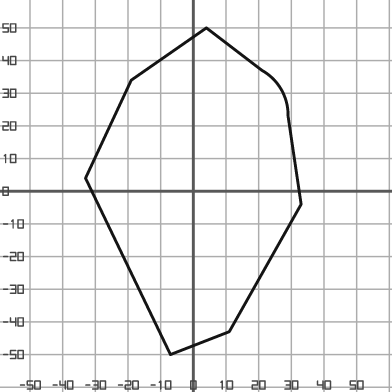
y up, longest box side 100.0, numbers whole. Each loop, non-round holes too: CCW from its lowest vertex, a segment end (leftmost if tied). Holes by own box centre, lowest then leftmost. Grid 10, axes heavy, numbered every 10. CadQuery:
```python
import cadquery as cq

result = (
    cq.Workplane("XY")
    .moveTo(-7.0, -50.0)
    .lineTo(11.0, -43.0)
    .lineTo(33.0, -4.0)
    .lineTo(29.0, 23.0)
    .threePointArc((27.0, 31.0), (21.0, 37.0))
    .lineTo(4.0, 50.0)
    .lineTo(-19.0, 34.0)
    .lineTo(-33.0, 4.0)
    .close()
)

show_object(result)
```